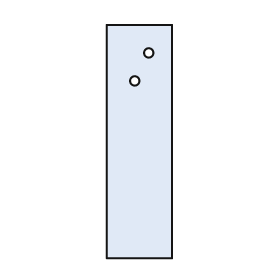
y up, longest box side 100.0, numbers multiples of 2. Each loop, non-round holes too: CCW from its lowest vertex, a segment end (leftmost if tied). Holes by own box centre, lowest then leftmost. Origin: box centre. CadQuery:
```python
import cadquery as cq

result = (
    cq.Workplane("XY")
    .moveTo(-14.0, -50.0)
    .lineTo(14.0, -50.0)
    .lineTo(14.0, 50.0)
    .lineTo(-14.0, 50.0)
    .close()
    .moveTo(-2.0, 26.0)
    .circle(2.0)
    .moveTo(4.0, 38.0)
    .circle(2.0)
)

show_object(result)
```